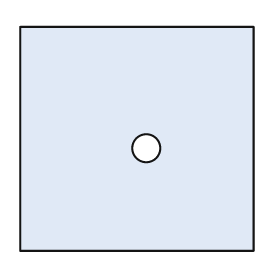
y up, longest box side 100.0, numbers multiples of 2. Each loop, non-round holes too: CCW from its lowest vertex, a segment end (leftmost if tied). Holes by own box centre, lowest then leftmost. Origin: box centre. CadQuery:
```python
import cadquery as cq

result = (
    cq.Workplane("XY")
    .moveTo(-50.0, -48.0)
    .lineTo(50.0, -48.0)
    .lineTo(50.0, 48.0)
    .lineTo(-50.0, 48.0)
    .close()
    .moveTo(4.0, -4.0)
    .circle(6.0)
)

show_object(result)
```